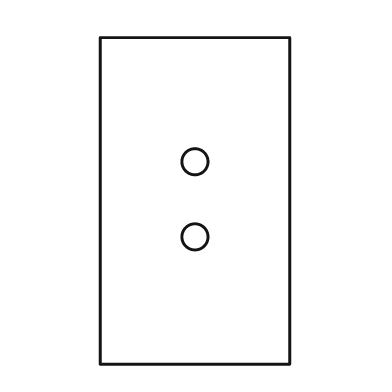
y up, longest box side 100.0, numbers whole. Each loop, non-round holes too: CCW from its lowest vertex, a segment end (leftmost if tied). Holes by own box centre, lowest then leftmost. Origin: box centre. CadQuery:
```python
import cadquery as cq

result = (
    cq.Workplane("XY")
    .moveTo(-29.0, -50.0)
    .lineTo(29.0, -50.0)
    .lineTo(29.0, 50.0)
    .lineTo(-29.0, 50.0)
    .close()
    .moveTo(0.0, -11.0)
    .circle(4.0)
    .moveTo(0.0, 12.0)
    .circle(4.0)
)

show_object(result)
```